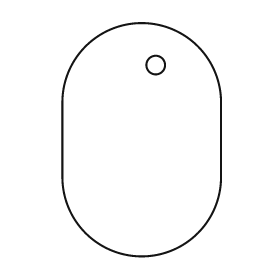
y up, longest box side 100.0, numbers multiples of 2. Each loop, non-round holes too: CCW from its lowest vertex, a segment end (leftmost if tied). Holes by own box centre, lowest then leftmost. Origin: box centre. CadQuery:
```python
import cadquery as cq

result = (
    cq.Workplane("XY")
    .moveTo(-34.0, -16.0)
    .threePointArc((0.0, -50.0), (34.0, -16.0))
    .lineTo(34.0, 16.0)
    .threePointArc((0.0, 50.0), (-34.0, 16.0))
    .close()
    .moveTo(6.0, 32.0)
    .circle(4.0)
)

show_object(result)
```